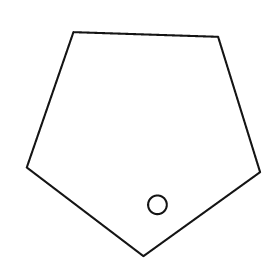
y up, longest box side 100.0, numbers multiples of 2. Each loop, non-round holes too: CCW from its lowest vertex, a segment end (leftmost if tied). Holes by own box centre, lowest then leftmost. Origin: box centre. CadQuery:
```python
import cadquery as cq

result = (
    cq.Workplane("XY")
    .moveTo(0.0, -48.0)
    .lineTo(50.0, -12.0)
    .lineTo(32.0, 46.0)
    .lineTo(-30.0, 48.0)
    .lineTo(-50.0, -10.0)
    .close()
    .moveTo(6.0, -26.0)
    .circle(4.0)
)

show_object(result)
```